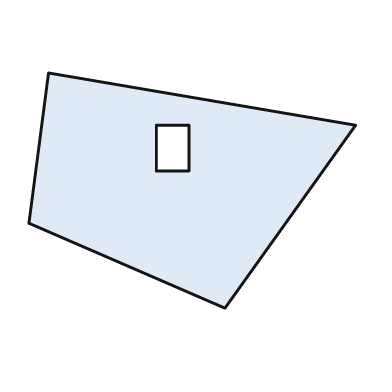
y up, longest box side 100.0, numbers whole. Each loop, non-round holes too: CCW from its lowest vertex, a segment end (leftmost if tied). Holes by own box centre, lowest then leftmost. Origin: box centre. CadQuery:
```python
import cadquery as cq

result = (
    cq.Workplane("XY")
    .moveTo(10.0, -36.0)
    .lineTo(50.0, 20.0)
    .lineTo(-44.0, 36.0)
    .lineTo(-50.0, -10.0)
    .close()
    .moveTo(-11.0, 6.0)
    .lineTo(-1.0, 6.0)
    .lineTo(-1.0, 20.0)
    .lineTo(-11.0, 20.0)
    .close()
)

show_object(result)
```